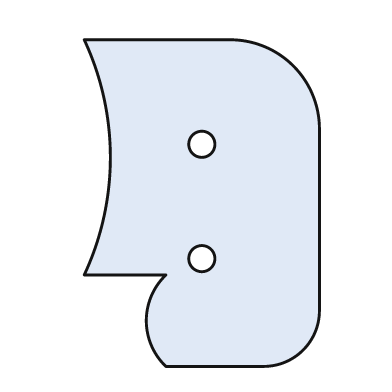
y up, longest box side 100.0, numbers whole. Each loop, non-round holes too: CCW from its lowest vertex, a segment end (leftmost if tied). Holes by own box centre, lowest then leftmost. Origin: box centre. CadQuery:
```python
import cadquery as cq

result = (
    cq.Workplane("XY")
    .moveTo(-11.0, -50.0)
    .lineTo(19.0, -50.0)
    .threePointArc((31.0, -45.0), (36.0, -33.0))
    .lineTo(36.0, 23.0)
    .threePointArc((28.0, 42.0), (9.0, 50.0))
    .lineTo(-36.0, 50.0)
    .threePointArc((-28.0, 14.0), (-36.0, -22.0))
    .lineTo(-11.0, -22.0)
    .threePointArc((-17.0, -36.0), (-11.0, -50.0))
    .close()
    .moveTo(0.0, -17.0)
    .circle(4.0)
    .moveTo(0.0, 18.0)
    .circle(4.0)
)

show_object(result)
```